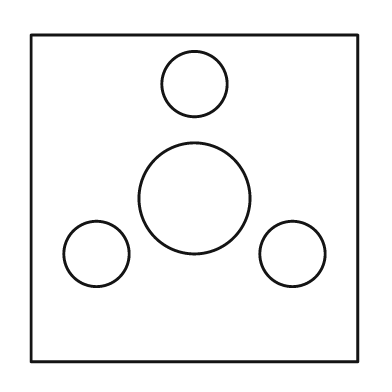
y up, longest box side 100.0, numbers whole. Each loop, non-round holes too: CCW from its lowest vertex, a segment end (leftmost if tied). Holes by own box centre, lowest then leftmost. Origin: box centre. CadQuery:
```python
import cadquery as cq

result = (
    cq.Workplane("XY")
    .moveTo(-50.0, -50.0)
    .lineTo(50.0, -50.0)
    .lineTo(50.0, 50.0)
    .lineTo(-50.0, 50.0)
    .close()
    .moveTo(-30.0, -17.0)
    .circle(10.0)
    .moveTo(30.0, -17.0)
    .circle(10.0)
    .moveTo(0.0, 0.0)
    .circle(17.0)
    .moveTo(0.0, 35.0)
    .circle(10.0)
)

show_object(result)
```